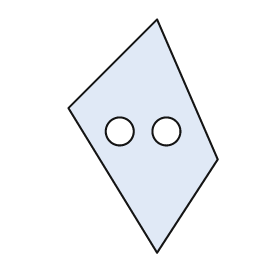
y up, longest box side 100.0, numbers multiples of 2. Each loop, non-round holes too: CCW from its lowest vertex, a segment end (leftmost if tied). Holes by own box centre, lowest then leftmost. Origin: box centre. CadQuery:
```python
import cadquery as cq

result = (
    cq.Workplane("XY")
    .moveTo(6.0, -50.0)
    .lineTo(32.0, -10.0)
    .lineTo(6.0, 50.0)
    .lineTo(-32.0, 12.0)
    .close()
    .moveTo(-10.0, 2.0)
    .circle(6.0)
    .moveTo(10.0, 2.0)
    .circle(6.0)
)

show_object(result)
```